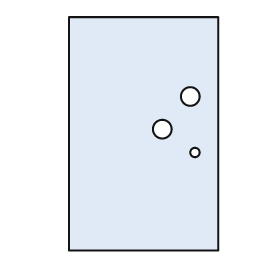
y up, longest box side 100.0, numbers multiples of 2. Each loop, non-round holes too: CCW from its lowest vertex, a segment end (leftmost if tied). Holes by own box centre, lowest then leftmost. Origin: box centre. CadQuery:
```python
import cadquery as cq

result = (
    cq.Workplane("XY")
    .moveTo(-32.0, -50.0)
    .lineTo(32.0, -50.0)
    .lineTo(32.0, 50.0)
    .lineTo(-32.0, 50.0)
    .close()
    .moveTo(22.0, -8.0)
    .circle(2.0)
    .moveTo(8.0, 2.0)
    .circle(4.0)
    .moveTo(20.0, 16.0)
    .circle(4.0)
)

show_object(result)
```